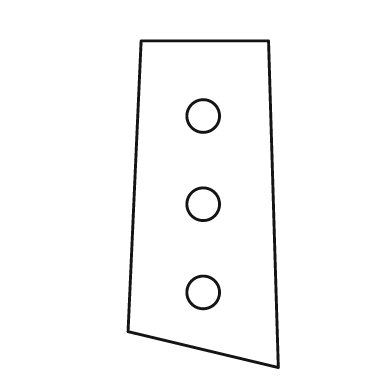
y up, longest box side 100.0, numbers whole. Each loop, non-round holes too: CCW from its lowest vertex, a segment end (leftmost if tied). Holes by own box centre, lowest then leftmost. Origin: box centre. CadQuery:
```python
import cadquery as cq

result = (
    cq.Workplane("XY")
    .moveTo(23.0, -50.0)
    .lineTo(20.0, 50.0)
    .lineTo(-19.0, 50.0)
    .lineTo(-23.0, -39.0)
    .close()
    .moveTo(0.0, -27.0)
    .circle(5.0)
    .moveTo(0.0, 0.0)
    .circle(5.0)
    .moveTo(0.0, 27.0)
    .circle(5.0)
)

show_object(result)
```